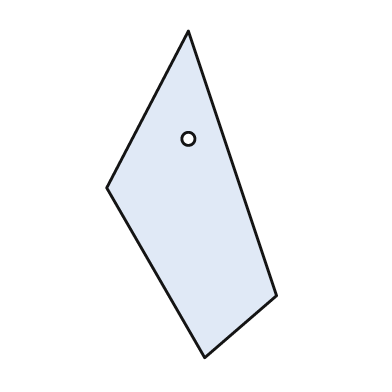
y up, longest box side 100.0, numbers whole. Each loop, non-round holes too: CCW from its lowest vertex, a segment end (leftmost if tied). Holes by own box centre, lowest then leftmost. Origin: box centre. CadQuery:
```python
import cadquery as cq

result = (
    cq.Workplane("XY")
    .moveTo(4.0, -50.0)
    .lineTo(26.0, -31.0)
    .lineTo(-1.0, 50.0)
    .lineTo(-26.0, 2.0)
    .close()
    .moveTo(-1.0, 17.0)
    .circle(2.0)
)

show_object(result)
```